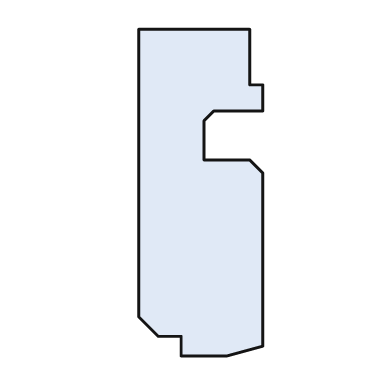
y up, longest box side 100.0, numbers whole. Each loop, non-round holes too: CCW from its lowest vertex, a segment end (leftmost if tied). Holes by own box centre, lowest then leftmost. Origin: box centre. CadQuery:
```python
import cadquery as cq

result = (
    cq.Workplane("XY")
    .moveTo(-6.0, -50.0)
    .lineTo(8.0, -50.0)
    .lineTo(19.0, -47.0)
    .lineTo(19.0, 6.0)
    .lineTo(15.0, 10.0)
    .lineTo(1.0, 10.0)
    .lineTo(1.0, 22.0)
    .lineTo(4.0, 25.0)
    .lineTo(19.0, 25.0)
    .lineTo(19.0, 33.0)
    .lineTo(15.0, 33.0)
    .lineTo(15.0, 50.0)
    .lineTo(-19.0, 50.0)
    .lineTo(-19.0, -38.0)
    .lineTo(-13.0, -44.0)
    .lineTo(-6.0, -44.0)
    .close()
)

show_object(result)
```